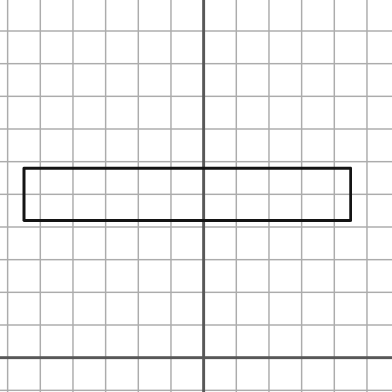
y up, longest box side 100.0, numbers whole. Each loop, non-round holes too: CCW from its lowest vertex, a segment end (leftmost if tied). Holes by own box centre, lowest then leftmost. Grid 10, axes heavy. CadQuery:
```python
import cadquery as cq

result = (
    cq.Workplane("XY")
    .moveTo(-55.0, 42.0)
    .lineTo(45.0, 42.0)
    .lineTo(45.0, 58.0)
    .lineTo(-55.0, 58.0)
    .close()
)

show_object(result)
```